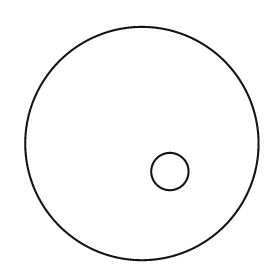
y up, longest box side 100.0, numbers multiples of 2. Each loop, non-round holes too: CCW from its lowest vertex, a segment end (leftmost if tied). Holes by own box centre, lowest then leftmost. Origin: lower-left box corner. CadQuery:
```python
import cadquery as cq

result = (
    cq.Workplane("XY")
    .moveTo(50.0, 50.0)
    .circle(50.0)
    .moveTo(62.0, 38.0)
    .circle(8.0)
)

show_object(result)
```